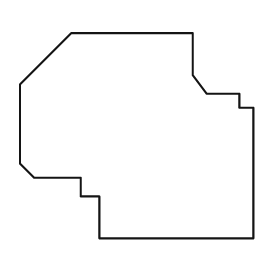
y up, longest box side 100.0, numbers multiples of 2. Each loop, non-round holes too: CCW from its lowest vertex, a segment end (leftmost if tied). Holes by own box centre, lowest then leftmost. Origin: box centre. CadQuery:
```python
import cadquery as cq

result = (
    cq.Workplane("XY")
    .moveTo(-16.0, -44.0)
    .lineTo(50.0, -44.0)
    .lineTo(50.0, 12.0)
    .lineTo(44.0, 12.0)
    .lineTo(44.0, 18.0)
    .lineTo(30.0, 18.0)
    .lineTo(24.0, 26.0)
    .lineTo(24.0, 44.0)
    .lineTo(-28.0, 44.0)
    .lineTo(-50.0, 22.0)
    .lineTo(-50.0, -12.0)
    .lineTo(-44.0, -18.0)
    .lineTo(-24.0, -18.0)
    .lineTo(-24.0, -26.0)
    .lineTo(-16.0, -26.0)
    .close()
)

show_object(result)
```